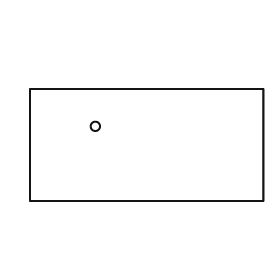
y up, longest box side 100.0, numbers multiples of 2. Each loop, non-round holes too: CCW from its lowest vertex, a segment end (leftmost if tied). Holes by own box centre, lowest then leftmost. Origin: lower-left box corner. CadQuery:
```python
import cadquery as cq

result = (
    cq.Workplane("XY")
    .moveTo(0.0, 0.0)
    .lineTo(100.0, 0.0)
    .lineTo(100.0, 48.0)
    .lineTo(0.0, 48.0)
    .close()
    .moveTo(28.0, 32.0)
    .circle(2.0)
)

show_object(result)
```